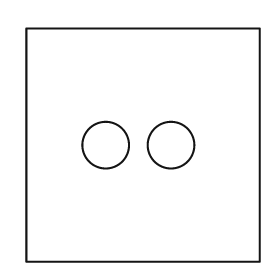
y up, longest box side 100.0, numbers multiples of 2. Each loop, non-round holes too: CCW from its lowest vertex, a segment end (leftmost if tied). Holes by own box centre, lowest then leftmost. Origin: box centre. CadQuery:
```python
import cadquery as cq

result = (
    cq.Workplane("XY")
    .moveTo(-50.0, -50.0)
    .lineTo(50.0, -50.0)
    .lineTo(50.0, 50.0)
    .lineTo(-50.0, 50.0)
    .close()
    .moveTo(-16.0, 0.0)
    .circle(10.0)
    .moveTo(12.0, 0.0)
    .circle(10.0)
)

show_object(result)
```